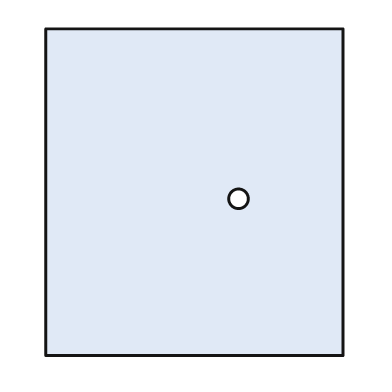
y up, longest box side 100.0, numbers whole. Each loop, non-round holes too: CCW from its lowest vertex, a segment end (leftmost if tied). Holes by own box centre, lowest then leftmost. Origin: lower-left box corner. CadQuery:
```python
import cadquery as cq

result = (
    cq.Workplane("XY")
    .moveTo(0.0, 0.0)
    .lineTo(91.0, 0.0)
    .lineTo(91.0, 100.0)
    .lineTo(0.0, 100.0)
    .close()
    .moveTo(59.0, 48.0)
    .circle(3.0)
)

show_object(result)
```